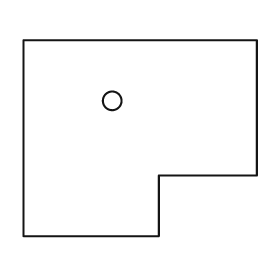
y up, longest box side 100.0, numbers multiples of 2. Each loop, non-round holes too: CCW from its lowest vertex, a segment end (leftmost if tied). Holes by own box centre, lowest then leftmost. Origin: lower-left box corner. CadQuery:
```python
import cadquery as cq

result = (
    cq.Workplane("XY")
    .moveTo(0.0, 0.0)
    .lineTo(58.0, 0.0)
    .lineTo(58.0, 26.0)
    .lineTo(100.0, 26.0)
    .lineTo(100.0, 84.0)
    .lineTo(0.0, 84.0)
    .close()
    .moveTo(38.0, 58.0)
    .circle(4.0)
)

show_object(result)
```